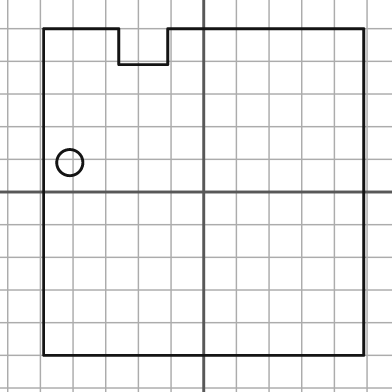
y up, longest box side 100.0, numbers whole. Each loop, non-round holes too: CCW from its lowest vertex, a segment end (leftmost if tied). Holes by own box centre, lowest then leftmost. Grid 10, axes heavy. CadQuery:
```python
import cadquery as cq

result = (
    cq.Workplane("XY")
    .moveTo(-49.0, -50.0)
    .lineTo(49.0, -50.0)
    .lineTo(49.0, 50.0)
    .lineTo(-11.0, 50.0)
    .lineTo(-11.0, 39.0)
    .lineTo(-26.0, 39.0)
    .lineTo(-26.0, 50.0)
    .lineTo(-49.0, 50.0)
    .close()
    .moveTo(-41.0, 9.0)
    .circle(4.0)
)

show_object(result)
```